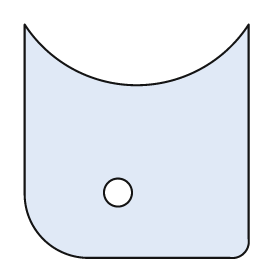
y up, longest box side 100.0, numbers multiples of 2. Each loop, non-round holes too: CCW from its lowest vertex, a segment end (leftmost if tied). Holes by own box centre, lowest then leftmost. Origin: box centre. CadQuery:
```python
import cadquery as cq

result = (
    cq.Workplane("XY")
    .moveTo(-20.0, -50.0)
    .lineTo(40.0, -50.0)
    .threePointArc((46.0, -48.0), (48.0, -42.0))
    .lineTo(48.0, 50.0)
    .threePointArc((0.0, 24.0), (-48.0, 50.0))
    .lineTo(-48.0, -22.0)
    .threePointArc((-40.0, -42.0), (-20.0, -50.0))
    .close()
    .moveTo(-8.0, -22.0)
    .circle(6.0)
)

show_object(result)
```